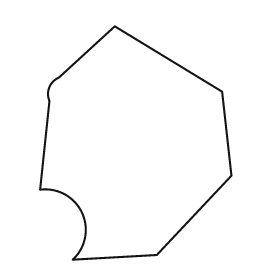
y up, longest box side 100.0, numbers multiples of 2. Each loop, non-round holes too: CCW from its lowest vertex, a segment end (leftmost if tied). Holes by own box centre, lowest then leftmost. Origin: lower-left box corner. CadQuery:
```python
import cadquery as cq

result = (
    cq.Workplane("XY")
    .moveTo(14.0, 0.0)
    .lineTo(50.0, 2.0)
    .lineTo(82.0, 36.0)
    .lineTo(78.0, 72.0)
    .lineTo(32.0, 100.0)
    .lineTo(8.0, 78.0)
    .threePointArc((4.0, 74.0), (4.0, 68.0))
    .lineTo(0.0, 30.0)
    .threePointArc((18.0, 20.0), (14.0, 0.0))
    .close()
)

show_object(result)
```